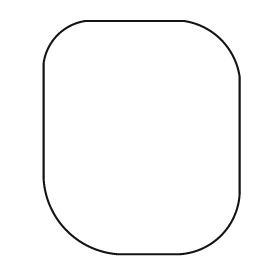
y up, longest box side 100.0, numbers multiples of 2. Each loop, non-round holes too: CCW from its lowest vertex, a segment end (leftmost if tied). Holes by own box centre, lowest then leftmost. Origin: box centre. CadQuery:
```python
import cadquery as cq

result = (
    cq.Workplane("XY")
    .moveTo(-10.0, -50.0)
    .lineTo(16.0, -50.0)
    .threePointArc((34.0, -42.0), (42.0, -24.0))
    .lineTo(42.0, 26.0)
    .threePointArc((34.0, 42.0), (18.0, 50.0))
    .lineTo(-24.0, 50.0)
    .threePointArc((-36.0, 44.0), (-42.0, 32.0))
    .lineTo(-42.0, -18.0)
    .threePointArc((-32.0, -40.0), (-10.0, -50.0))
    .close()
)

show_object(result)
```